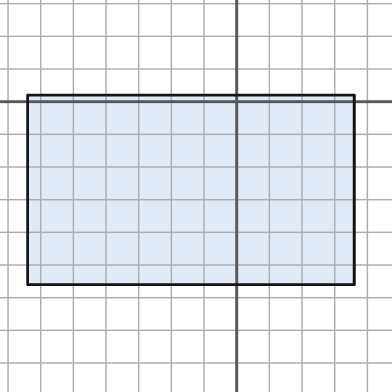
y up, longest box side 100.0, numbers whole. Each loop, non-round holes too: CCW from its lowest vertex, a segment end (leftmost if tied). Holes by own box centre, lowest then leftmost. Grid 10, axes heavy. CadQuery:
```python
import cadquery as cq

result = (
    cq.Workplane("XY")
    .moveTo(-64.0, -56.0)
    .lineTo(36.0, -56.0)
    .lineTo(36.0, 2.0)
    .lineTo(-64.0, 2.0)
    .close()
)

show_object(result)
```